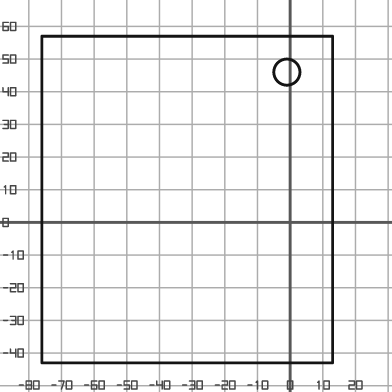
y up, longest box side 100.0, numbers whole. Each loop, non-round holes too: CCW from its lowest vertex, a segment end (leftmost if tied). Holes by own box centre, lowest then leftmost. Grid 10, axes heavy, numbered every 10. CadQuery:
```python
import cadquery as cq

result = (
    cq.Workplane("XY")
    .moveTo(-76.0, -43.0)
    .lineTo(13.0, -43.0)
    .lineTo(13.0, 57.0)
    .lineTo(-76.0, 57.0)
    .close()
    .moveTo(-1.0, 46.0)
    .circle(4.0)
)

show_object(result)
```